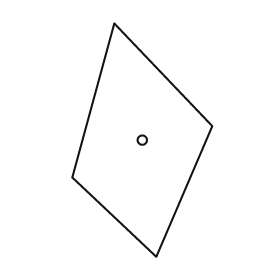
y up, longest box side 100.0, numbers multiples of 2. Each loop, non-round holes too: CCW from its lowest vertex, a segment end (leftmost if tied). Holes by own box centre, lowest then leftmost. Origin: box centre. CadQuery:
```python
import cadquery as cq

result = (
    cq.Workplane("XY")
    .moveTo(6.0, -50.0)
    .lineTo(30.0, 6.0)
    .lineTo(-12.0, 50.0)
    .lineTo(-30.0, -16.0)
    .close()
    .moveTo(0.0, 0.0)
    .circle(2.0)
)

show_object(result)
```